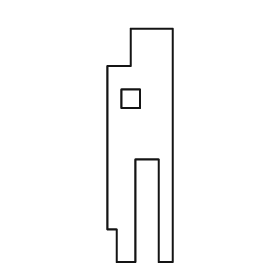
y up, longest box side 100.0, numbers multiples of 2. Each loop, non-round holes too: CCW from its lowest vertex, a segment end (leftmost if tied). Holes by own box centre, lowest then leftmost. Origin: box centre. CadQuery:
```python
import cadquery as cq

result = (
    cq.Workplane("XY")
    .moveTo(-10.0, -50.0)
    .lineTo(-2.0, -50.0)
    .lineTo(-2.0, -6.0)
    .lineTo(8.0, -6.0)
    .lineTo(8.0, -50.0)
    .lineTo(14.0, -50.0)
    .lineTo(14.0, 50.0)
    .lineTo(-4.0, 50.0)
    .lineTo(-4.0, 34.0)
    .lineTo(-14.0, 34.0)
    .lineTo(-14.0, -36.0)
    .lineTo(-10.0, -36.0)
    .close()
    .moveTo(-8.0, 16.0)
    .lineTo(0.0, 16.0)
    .lineTo(0.0, 24.0)
    .lineTo(-8.0, 24.0)
    .close()
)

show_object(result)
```